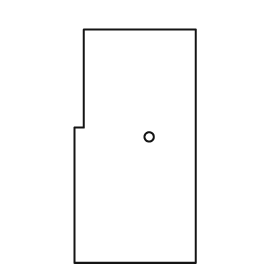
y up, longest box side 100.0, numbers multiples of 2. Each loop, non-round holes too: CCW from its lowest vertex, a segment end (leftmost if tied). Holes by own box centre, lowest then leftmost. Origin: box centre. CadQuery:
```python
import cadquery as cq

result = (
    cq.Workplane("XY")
    .moveTo(-26.0, -50.0)
    .lineTo(26.0, -50.0)
    .lineTo(26.0, 50.0)
    .lineTo(-22.0, 50.0)
    .lineTo(-22.0, 8.0)
    .lineTo(-26.0, 8.0)
    .close()
    .moveTo(6.0, 4.0)
    .circle(2.0)
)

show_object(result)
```